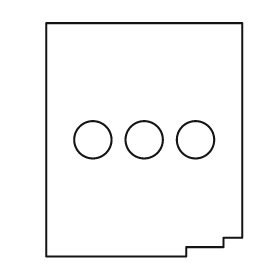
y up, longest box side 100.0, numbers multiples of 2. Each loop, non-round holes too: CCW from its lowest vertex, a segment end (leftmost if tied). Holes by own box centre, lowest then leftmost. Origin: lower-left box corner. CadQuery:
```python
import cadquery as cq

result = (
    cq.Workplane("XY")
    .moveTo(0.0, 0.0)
    .lineTo(60.0, 0.0)
    .lineTo(60.0, 4.0)
    .lineTo(76.0, 4.0)
    .lineTo(76.0, 8.0)
    .lineTo(84.0, 8.0)
    .lineTo(84.0, 100.0)
    .lineTo(0.0, 100.0)
    .close()
    .moveTo(20.0, 50.0)
    .circle(8.0)
    .moveTo(42.0, 50.0)
    .circle(8.0)
    .moveTo(64.0, 50.0)
    .circle(8.0)
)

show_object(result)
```